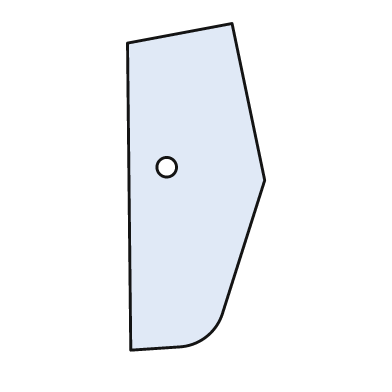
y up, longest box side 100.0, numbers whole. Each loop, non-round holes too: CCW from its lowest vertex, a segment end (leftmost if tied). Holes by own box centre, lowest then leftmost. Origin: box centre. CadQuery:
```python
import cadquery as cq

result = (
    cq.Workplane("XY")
    .moveTo(-20.0, -50.0)
    .lineTo(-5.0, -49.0)
    .threePointArc((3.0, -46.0), (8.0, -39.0))
    .lineTo(21.0, 2.0)
    .lineTo(11.0, 50.0)
    .lineTo(-21.0, 44.0)
    .close()
    .moveTo(-9.0, 6.0)
    .circle(3.0)
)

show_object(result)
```